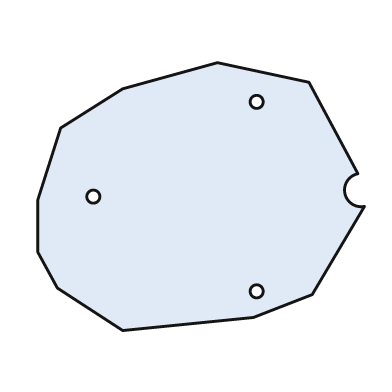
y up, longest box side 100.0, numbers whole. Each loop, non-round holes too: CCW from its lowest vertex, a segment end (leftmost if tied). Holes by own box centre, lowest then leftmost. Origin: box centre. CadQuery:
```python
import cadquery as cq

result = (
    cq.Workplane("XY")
    .moveTo(-24.0, -41.0)
    .lineTo(16.0, -37.0)
    .lineTo(34.0, -30.0)
    .lineTo(50.0, -3.0)
    .threePointArc((44.0, 1.0), (48.0, 7.0))
    .lineTo(33.0, 35.0)
    .lineTo(5.0, 41.0)
    .lineTo(-24.0, 33.0)
    .lineTo(-43.0, 21.0)
    .lineTo(-50.0, -1.0)
    .lineTo(-50.0, -17.0)
    .lineTo(-44.0, -28.0)
    .close()
    .moveTo(17.0, -29.0)
    .circle(2.0)
    .moveTo(-33.0, 0.0)
    .circle(2.0)
    .moveTo(17.0, 29.0)
    .circle(2.0)
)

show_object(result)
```